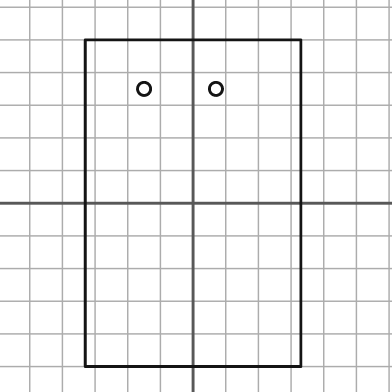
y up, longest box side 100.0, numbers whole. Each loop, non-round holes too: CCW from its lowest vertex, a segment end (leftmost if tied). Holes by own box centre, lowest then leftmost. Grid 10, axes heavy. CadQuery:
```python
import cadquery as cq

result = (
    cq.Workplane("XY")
    .moveTo(-33.0, -50.0)
    .lineTo(33.0, -50.0)
    .lineTo(33.0, 50.0)
    .lineTo(-33.0, 50.0)
    .close()
    .moveTo(-15.0, 35.0)
    .circle(2.0)
    .moveTo(7.0, 35.0)
    .circle(2.0)
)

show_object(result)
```